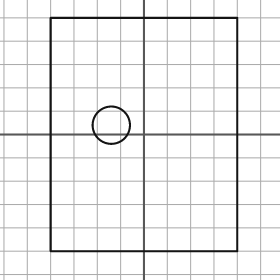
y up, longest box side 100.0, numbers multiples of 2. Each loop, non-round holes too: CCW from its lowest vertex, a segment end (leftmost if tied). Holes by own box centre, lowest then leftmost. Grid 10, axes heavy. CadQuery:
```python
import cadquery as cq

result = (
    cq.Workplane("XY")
    .moveTo(-40.0, -50.0)
    .lineTo(40.0, -50.0)
    .lineTo(40.0, 50.0)
    .lineTo(-40.0, 50.0)
    .close()
    .moveTo(-14.0, 4.0)
    .circle(8.0)
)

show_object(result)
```